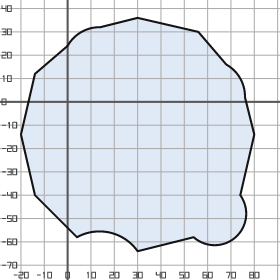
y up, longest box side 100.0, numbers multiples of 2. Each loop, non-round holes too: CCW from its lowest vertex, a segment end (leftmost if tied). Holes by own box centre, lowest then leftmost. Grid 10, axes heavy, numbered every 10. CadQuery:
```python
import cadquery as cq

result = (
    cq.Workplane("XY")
    .moveTo(30.0, -64.0)
    .lineTo(54.0, -58.0)
    .threePointArc((72.0, -58.0), (74.0, -40.0))
    .lineTo(80.0, -14.0)
    .lineTo(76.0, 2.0)
    .threePointArc((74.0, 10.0), (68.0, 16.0))
    .lineTo(56.0, 30.0)
    .lineTo(30.0, 36.0)
    .lineTo(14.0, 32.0)
    .threePointArc((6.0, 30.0), (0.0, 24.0))
    .lineTo(-14.0, 12.0)
    .lineTo(-20.0, -14.0)
    .lineTo(-14.0, -40.0)
    .lineTo(4.0, -58.0)
    .threePointArc((18.0, -56.0), (30.0, -64.0))
    .close()
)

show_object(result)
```